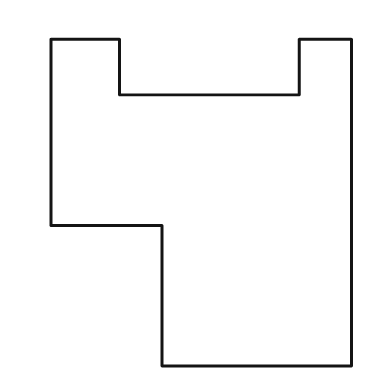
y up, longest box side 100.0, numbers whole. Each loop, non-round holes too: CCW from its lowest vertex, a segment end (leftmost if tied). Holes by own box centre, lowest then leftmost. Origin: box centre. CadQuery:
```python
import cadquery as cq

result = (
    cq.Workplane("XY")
    .moveTo(-12.0, -50.0)
    .lineTo(46.0, -50.0)
    .lineTo(46.0, 50.0)
    .lineTo(30.0, 50.0)
    .lineTo(30.0, 33.0)
    .lineTo(-25.0, 33.0)
    .lineTo(-25.0, 50.0)
    .lineTo(-46.0, 50.0)
    .lineTo(-46.0, -7.0)
    .lineTo(-12.0, -7.0)
    .close()
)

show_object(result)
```